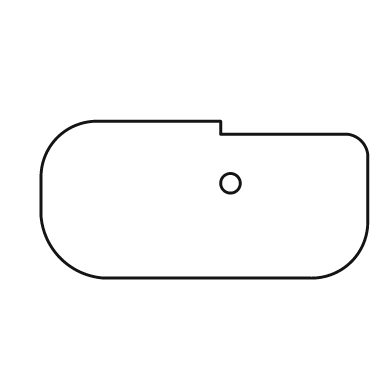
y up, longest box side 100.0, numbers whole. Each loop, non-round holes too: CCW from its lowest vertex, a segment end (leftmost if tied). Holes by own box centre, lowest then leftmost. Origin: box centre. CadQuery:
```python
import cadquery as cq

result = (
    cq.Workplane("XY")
    .moveTo(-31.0, -24.0)
    .lineTo(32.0, -24.0)
    .threePointArc((45.0, -19.0), (50.0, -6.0))
    .lineTo(50.0, 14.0)
    .threePointArc((48.0, 18.0), (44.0, 20.0))
    .lineTo(5.0, 20.0)
    .lineTo(5.0, 24.0)
    .lineTo(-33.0, 24.0)
    .threePointArc((-45.0, 19.0), (-50.0, 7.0))
    .lineTo(-50.0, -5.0)
    .threePointArc((-44.0, -18.0), (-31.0, -24.0))
    .close()
    .moveTo(8.0, 5.0)
    .circle(3.0)
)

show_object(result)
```